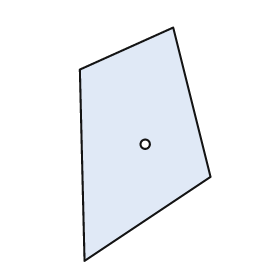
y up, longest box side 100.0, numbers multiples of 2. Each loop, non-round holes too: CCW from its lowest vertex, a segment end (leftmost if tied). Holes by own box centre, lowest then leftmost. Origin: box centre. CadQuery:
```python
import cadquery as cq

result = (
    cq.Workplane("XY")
    .moveTo(-26.0, -50.0)
    .lineTo(28.0, -14.0)
    .lineTo(12.0, 50.0)
    .lineTo(-28.0, 32.0)
    .close()
    .moveTo(0.0, 0.0)
    .circle(2.0)
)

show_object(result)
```